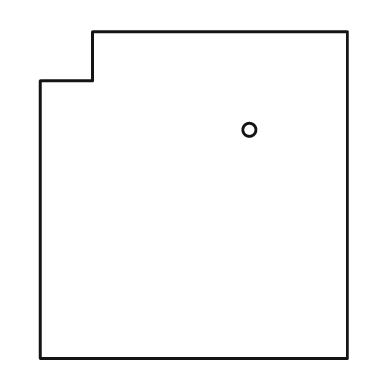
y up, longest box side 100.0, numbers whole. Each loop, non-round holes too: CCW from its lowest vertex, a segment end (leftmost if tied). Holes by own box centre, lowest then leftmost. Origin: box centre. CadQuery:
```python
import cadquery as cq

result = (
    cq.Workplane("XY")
    .moveTo(-47.0, -50.0)
    .lineTo(47.0, -50.0)
    .lineTo(47.0, 50.0)
    .lineTo(-31.0, 50.0)
    .lineTo(-31.0, 35.0)
    .lineTo(-47.0, 35.0)
    .close()
    .moveTo(17.0, 20.0)
    .circle(2.0)
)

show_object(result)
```